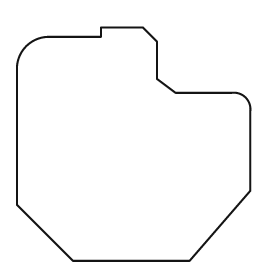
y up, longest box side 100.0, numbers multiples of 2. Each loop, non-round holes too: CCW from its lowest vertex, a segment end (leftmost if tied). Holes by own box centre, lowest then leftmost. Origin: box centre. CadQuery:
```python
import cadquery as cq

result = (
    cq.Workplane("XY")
    .moveTo(-26.0, -50.0)
    .lineTo(24.0, -50.0)
    .lineTo(50.0, -20.0)
    .lineTo(50.0, 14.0)
    .threePointArc((48.0, 20.0), (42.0, 22.0))
    .lineTo(18.0, 22.0)
    .lineTo(10.0, 28.0)
    .lineTo(10.0, 44.0)
    .lineTo(4.0, 50.0)
    .lineTo(-14.0, 50.0)
    .lineTo(-14.0, 46.0)
    .lineTo(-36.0, 46.0)
    .threePointArc((-46.0, 42.0), (-50.0, 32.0))
    .lineTo(-50.0, -26.0)
    .close()
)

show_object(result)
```